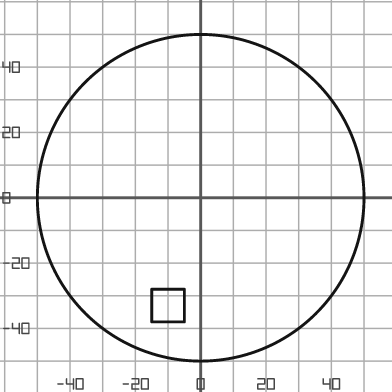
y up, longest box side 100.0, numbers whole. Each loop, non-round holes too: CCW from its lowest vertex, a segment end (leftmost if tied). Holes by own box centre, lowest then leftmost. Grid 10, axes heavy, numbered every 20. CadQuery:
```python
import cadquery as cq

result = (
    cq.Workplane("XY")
    .moveTo(0.0, 0.0)
    .circle(50.0)
    .moveTo(-15.0, -38.0)
    .lineTo(-5.0, -38.0)
    .lineTo(-5.0, -28.0)
    .lineTo(-15.0, -28.0)
    .close()
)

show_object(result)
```